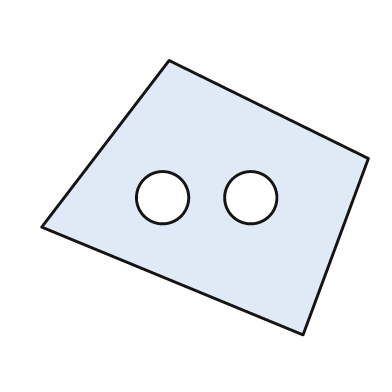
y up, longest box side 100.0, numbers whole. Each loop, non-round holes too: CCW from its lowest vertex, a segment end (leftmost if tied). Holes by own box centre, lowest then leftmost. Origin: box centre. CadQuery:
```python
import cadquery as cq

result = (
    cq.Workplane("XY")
    .moveTo(30.0, -42.0)
    .lineTo(50.0, 12.0)
    .lineTo(-11.0, 42.0)
    .lineTo(-50.0, -9.0)
    .close()
    .moveTo(-13.0, 0.0)
    .circle(8.0)
    .moveTo(14.0, 0.0)
    .circle(8.0)
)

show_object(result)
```